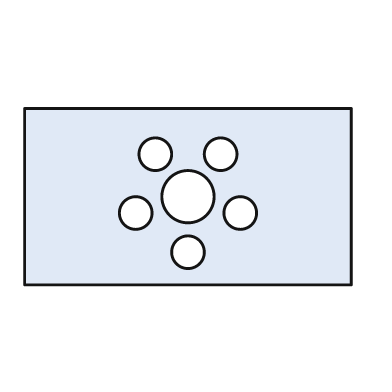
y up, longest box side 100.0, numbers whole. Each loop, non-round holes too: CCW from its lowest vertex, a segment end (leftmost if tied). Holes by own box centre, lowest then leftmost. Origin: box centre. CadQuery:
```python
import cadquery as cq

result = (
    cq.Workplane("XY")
    .moveTo(-50.0, -27.0)
    .lineTo(50.0, -27.0)
    .lineTo(50.0, 27.0)
    .lineTo(-50.0, 27.0)
    .close()
    .moveTo(0.0, -17.0)
    .circle(5.0)
    .moveTo(-16.0, -5.0)
    .circle(5.0)
    .moveTo(16.0, -5.0)
    .circle(5.0)
    .moveTo(0.0, 0.0)
    .circle(8.0)
    .moveTo(-10.0, 13.0)
    .circle(5.0)
    .moveTo(10.0, 13.0)
    .circle(5.0)
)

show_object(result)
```